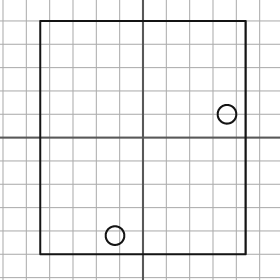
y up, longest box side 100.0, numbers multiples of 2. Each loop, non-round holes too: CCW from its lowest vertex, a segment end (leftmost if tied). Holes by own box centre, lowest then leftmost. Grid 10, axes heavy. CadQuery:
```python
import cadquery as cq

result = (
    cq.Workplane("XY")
    .moveTo(-44.0, -50.0)
    .lineTo(44.0, -50.0)
    .lineTo(44.0, 50.0)
    .lineTo(-44.0, 50.0)
    .close()
    .moveTo(-12.0, -42.0)
    .circle(4.0)
    .moveTo(36.0, 10.0)
    .circle(4.0)
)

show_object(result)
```